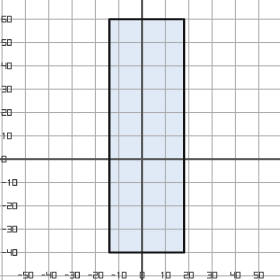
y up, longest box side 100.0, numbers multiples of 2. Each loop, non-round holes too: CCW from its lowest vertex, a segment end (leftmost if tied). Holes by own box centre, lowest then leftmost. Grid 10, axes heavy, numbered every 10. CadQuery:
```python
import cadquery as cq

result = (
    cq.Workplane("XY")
    .moveTo(-14.0, -40.0)
    .lineTo(18.0, -40.0)
    .lineTo(18.0, 60.0)
    .lineTo(-14.0, 60.0)
    .close()
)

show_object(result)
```